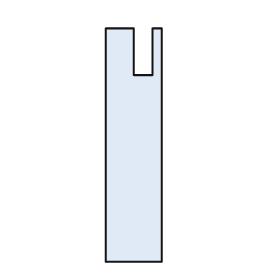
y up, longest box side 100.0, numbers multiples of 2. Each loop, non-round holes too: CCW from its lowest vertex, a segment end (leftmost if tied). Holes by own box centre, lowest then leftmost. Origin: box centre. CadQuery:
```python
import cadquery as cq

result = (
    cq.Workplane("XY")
    .moveTo(-12.0, -50.0)
    .lineTo(12.0, -50.0)
    .lineTo(12.0, 50.0)
    .lineTo(8.0, 50.0)
    .lineTo(8.0, 30.0)
    .lineTo(0.0, 30.0)
    .lineTo(0.0, 50.0)
    .lineTo(-12.0, 50.0)
    .close()
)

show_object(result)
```